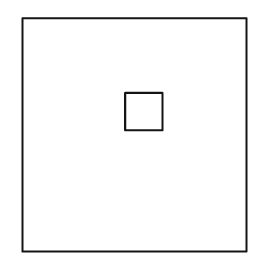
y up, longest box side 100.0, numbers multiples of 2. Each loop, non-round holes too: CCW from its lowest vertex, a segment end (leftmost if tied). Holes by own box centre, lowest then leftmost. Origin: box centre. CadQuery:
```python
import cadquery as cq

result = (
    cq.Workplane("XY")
    .moveTo(-48.0, -50.0)
    .lineTo(48.0, -50.0)
    .lineTo(48.0, 50.0)
    .lineTo(-48.0, 50.0)
    .close()
    .moveTo(-4.0, 2.0)
    .lineTo(12.0, 2.0)
    .lineTo(12.0, 18.0)
    .lineTo(-4.0, 18.0)
    .close()
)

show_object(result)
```